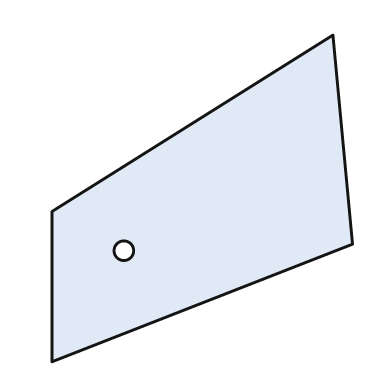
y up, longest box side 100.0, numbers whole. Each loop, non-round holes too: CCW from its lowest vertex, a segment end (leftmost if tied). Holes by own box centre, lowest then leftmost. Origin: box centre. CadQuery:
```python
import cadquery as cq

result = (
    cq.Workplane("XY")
    .moveTo(-46.0, -50.0)
    .lineTo(46.0, -14.0)
    .lineTo(40.0, 50.0)
    .lineTo(-46.0, -4.0)
    .close()
    .moveTo(-24.0, -16.0)
    .circle(3.0)
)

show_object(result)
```